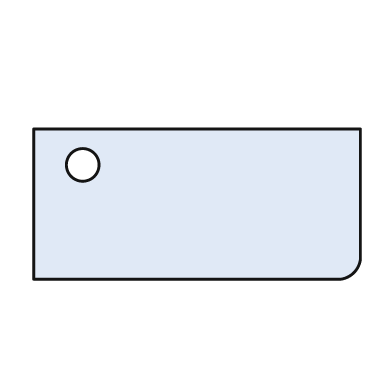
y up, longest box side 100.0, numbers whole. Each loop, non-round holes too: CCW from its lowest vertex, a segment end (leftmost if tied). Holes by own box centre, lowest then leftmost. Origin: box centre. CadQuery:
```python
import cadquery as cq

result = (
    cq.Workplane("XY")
    .moveTo(-50.0, -23.0)
    .lineTo(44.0, -23.0)
    .threePointArc((48.0, -21.0), (50.0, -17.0))
    .lineTo(50.0, 23.0)
    .lineTo(-50.0, 23.0)
    .close()
    .moveTo(-35.0, 12.0)
    .circle(5.0)
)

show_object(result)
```